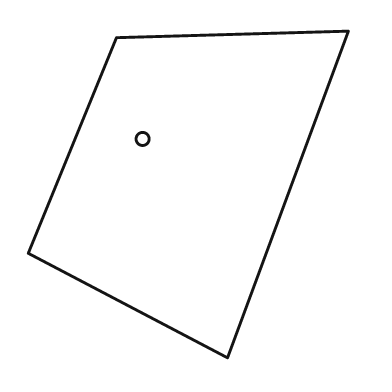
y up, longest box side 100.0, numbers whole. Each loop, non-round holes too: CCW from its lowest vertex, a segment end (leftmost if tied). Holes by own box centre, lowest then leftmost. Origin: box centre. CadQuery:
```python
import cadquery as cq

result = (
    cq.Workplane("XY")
    .moveTo(12.0, -50.0)
    .lineTo(49.0, 50.0)
    .lineTo(-22.0, 48.0)
    .lineTo(-49.0, -18.0)
    .close()
    .moveTo(-14.0, 17.0)
    .circle(2.0)
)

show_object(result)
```